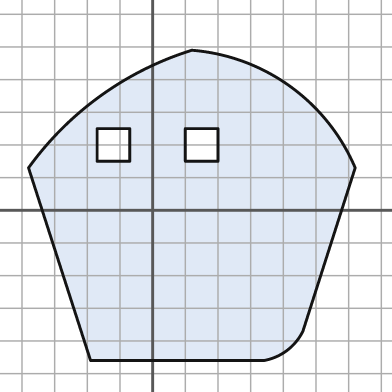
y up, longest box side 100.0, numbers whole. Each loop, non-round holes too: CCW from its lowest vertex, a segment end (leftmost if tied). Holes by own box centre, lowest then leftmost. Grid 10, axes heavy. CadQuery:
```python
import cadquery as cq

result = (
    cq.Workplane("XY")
    .moveTo(-19.0, -46.0)
    .lineTo(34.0, -46.0)
    .threePointArc((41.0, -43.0), (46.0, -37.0))
    .lineTo(62.0, 13.0)
    .threePointArc((42.0, 38.0), (12.0, 49.0))
    .threePointArc((-16.0, 35.0), (-38.0, 13.0))
    .close()
    .moveTo(-17.0, 15.0)
    .lineTo(-7.0, 15.0)
    .lineTo(-7.0, 25.0)
    .lineTo(-17.0, 25.0)
    .close()
    .moveTo(10.0, 15.0)
    .lineTo(20.0, 15.0)
    .lineTo(20.0, 25.0)
    .lineTo(10.0, 25.0)
    .close()
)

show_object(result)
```